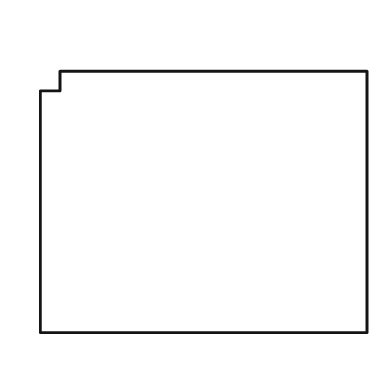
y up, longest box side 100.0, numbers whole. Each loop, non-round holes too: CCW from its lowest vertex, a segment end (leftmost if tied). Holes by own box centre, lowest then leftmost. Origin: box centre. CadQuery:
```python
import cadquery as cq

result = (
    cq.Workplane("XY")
    .moveTo(-50.0, -40.0)
    .lineTo(50.0, -40.0)
    .lineTo(50.0, 40.0)
    .lineTo(-44.0, 40.0)
    .lineTo(-44.0, 34.0)
    .lineTo(-50.0, 34.0)
    .close()
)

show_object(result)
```